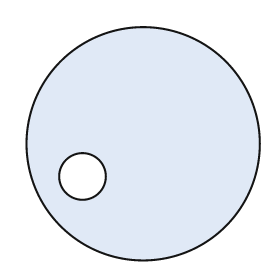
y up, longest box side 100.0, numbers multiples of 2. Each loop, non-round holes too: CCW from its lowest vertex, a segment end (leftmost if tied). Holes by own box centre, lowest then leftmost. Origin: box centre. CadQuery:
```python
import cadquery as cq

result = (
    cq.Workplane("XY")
    .moveTo(0.0, 0.0)
    .circle(50.0)
    .moveTo(-26.0, -14.0)
    .circle(10.0)
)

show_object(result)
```